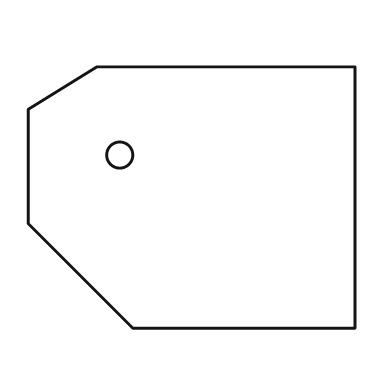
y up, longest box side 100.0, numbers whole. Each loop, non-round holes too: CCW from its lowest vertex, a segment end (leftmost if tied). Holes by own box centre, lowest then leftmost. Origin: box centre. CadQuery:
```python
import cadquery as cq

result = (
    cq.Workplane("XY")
    .moveTo(-18.0, -40.0)
    .lineTo(50.0, -40.0)
    .lineTo(50.0, 40.0)
    .lineTo(-29.0, 40.0)
    .lineTo(-50.0, 27.0)
    .lineTo(-50.0, -8.0)
    .close()
    .moveTo(-22.0, 13.0)
    .circle(4.0)
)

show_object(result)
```